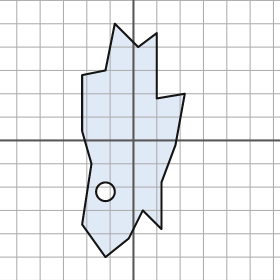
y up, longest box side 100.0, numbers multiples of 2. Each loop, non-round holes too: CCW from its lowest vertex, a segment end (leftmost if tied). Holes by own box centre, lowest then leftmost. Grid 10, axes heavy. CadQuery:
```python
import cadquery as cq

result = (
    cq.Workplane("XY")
    .moveTo(-12.0, -50.0)
    .lineTo(-2.0, -42.0)
    .lineTo(4.0, -30.0)
    .lineTo(12.0, -38.0)
    .lineTo(12.0, -18.0)
    .lineTo(18.0, -2.0)
    .lineTo(22.0, 20.0)
    .lineTo(10.0, 18.0)
    .lineTo(10.0, 46.0)
    .lineTo(2.0, 40.0)
    .lineTo(-8.0, 50.0)
    .lineTo(-12.0, 30.0)
    .lineTo(-22.0, 28.0)
    .lineTo(-22.0, 4.0)
    .lineTo(-18.0, -10.0)
    .lineTo(-22.0, -36.0)
    .close()
    .moveTo(-12.0, -22.0)
    .circle(4.0)
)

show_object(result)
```